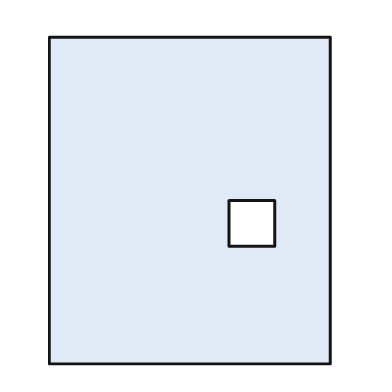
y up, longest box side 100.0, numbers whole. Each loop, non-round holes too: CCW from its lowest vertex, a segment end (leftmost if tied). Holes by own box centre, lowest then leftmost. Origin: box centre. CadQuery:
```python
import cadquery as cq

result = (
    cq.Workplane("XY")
    .moveTo(-43.0, -50.0)
    .lineTo(43.0, -50.0)
    .lineTo(43.0, 50.0)
    .lineTo(-43.0, 50.0)
    .close()
    .moveTo(12.0, -14.0)
    .lineTo(26.0, -14.0)
    .lineTo(26.0, 0.0)
    .lineTo(12.0, 0.0)
    .close()
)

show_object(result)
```